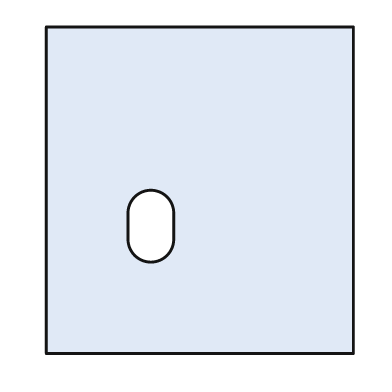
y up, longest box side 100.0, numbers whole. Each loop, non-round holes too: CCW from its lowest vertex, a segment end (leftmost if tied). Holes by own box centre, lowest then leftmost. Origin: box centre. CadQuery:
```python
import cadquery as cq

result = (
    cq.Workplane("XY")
    .moveTo(-47.0, -50.0)
    .lineTo(47.0, -50.0)
    .lineTo(47.0, 50.0)
    .lineTo(-47.0, 50.0)
    .close()
    .moveTo(-22.0, -15.0)
    .threePointArc((-15.0, -22.0), (-8.0, -15.0))
    .lineTo(-8.0, -7.0)
    .threePointArc((-15.0, 0.0), (-22.0, -7.0))
    .close()
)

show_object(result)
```